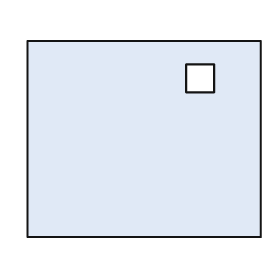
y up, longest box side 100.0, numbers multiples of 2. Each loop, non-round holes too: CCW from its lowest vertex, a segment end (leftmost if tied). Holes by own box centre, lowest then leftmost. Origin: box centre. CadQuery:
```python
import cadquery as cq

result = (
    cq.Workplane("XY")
    .moveTo(-50.0, -42.0)
    .lineTo(50.0, -42.0)
    .lineTo(50.0, 42.0)
    .lineTo(-50.0, 42.0)
    .close()
    .moveTo(18.0, 20.0)
    .lineTo(30.0, 20.0)
    .lineTo(30.0, 32.0)
    .lineTo(18.0, 32.0)
    .close()
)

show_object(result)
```